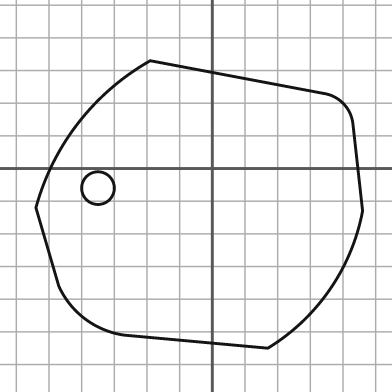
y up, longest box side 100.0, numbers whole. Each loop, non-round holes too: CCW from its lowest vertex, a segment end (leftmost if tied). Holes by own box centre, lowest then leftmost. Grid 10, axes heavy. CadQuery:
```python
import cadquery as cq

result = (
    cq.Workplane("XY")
    .moveTo(17.0, -55.0)
    .threePointArc((36.0, -37.0), (46.0, -13.0))
    .lineTo(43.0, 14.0)
    .threePointArc((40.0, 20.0), (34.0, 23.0))
    .lineTo(-19.0, 33.0)
    .threePointArc((-41.0, 14.0), (-54.0, -12.0))
    .lineTo(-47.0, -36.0)
    .threePointArc((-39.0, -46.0), (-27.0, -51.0))
    .close()
    .moveTo(-35.0, -6.0)
    .circle(5.0)
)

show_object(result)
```